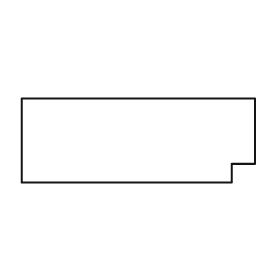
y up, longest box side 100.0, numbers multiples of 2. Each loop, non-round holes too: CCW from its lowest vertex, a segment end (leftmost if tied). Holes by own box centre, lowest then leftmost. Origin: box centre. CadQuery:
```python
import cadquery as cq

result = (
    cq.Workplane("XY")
    .moveTo(-50.0, -18.0)
    .lineTo(40.0, -18.0)
    .lineTo(40.0, -10.0)
    .lineTo(50.0, -10.0)
    .lineTo(50.0, 18.0)
    .lineTo(-50.0, 18.0)
    .close()
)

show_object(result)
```